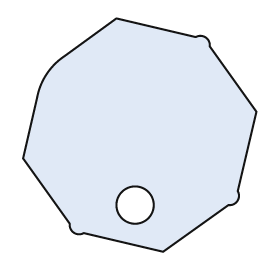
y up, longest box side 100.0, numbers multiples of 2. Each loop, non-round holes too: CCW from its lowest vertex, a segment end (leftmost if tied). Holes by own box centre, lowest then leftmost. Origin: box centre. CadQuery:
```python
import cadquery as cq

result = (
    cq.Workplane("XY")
    .moveTo(10.0, -50.0)
    .lineTo(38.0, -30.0)
    .threePointArc((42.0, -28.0), (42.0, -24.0))
    .lineTo(50.0, 10.0)
    .lineTo(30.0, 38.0)
    .threePointArc((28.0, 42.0), (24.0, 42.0))
    .lineTo(-10.0, 50.0)
    .lineTo(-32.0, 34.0)
    .threePointArc((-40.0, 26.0), (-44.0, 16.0))
    .lineTo(-50.0, -10.0)
    .lineTo(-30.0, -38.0)
    .threePointArc((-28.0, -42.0), (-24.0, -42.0))
    .close()
    .moveTo(-2.0, -30.0)
    .circle(8.0)
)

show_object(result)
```